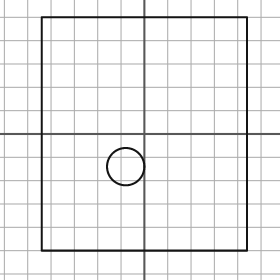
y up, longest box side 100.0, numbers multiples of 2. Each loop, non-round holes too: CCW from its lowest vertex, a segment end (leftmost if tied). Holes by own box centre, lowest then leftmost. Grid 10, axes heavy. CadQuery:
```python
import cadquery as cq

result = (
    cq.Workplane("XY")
    .moveTo(-44.0, -50.0)
    .lineTo(44.0, -50.0)
    .lineTo(44.0, 50.0)
    .lineTo(-44.0, 50.0)
    .close()
    .moveTo(-8.0, -14.0)
    .circle(8.0)
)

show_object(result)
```